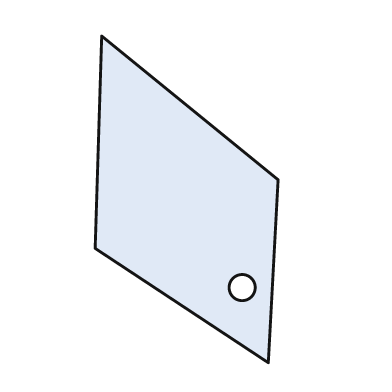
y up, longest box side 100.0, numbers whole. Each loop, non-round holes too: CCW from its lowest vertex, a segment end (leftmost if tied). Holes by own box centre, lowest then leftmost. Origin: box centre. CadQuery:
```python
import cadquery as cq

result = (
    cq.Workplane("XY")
    .moveTo(25.0, -50.0)
    .lineTo(28.0, 6.0)
    .lineTo(-26.0, 50.0)
    .lineTo(-28.0, -15.0)
    .close()
    .moveTo(17.0, -27.0)
    .circle(4.0)
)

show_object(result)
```